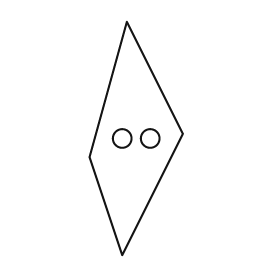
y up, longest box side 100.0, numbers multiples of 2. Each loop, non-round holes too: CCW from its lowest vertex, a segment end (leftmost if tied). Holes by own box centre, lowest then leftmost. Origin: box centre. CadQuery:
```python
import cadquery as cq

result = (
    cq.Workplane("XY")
    .moveTo(-6.0, -50.0)
    .lineTo(20.0, 2.0)
    .lineTo(-4.0, 50.0)
    .lineTo(-20.0, -8.0)
    .close()
    .moveTo(-6.0, 0.0)
    .circle(4.0)
    .moveTo(6.0, 0.0)
    .circle(4.0)
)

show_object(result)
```